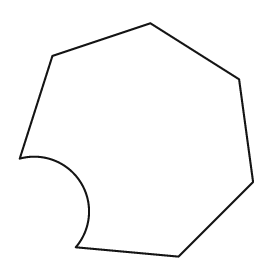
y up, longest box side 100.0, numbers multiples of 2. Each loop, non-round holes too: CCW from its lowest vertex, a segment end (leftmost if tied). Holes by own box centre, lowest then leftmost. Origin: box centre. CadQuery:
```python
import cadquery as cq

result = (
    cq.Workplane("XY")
    .moveTo(18.0, -50.0)
    .lineTo(50.0, -18.0)
    .lineTo(44.0, 26.0)
    .lineTo(6.0, 50.0)
    .lineTo(-36.0, 36.0)
    .lineTo(-50.0, -8.0)
    .threePointArc((-24.0, -18.0), (-26.0, -46.0))
    .close()
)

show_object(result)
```